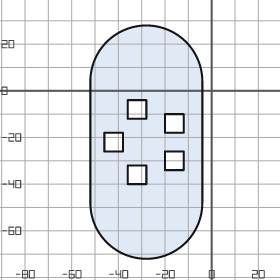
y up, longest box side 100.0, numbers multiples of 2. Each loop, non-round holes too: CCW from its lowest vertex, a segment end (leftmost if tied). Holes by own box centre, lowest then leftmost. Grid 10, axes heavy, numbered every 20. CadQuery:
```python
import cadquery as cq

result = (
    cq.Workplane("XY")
    .moveTo(-52.0, -48.0)
    .threePointArc((-28.0, -72.0), (-4.0, -48.0))
    .lineTo(-4.0, 4.0)
    .threePointArc((-28.0, 28.0), (-52.0, 4.0))
    .close()
    .moveTo(-36.0, -40.0)
    .lineTo(-28.0, -40.0)
    .lineTo(-28.0, -32.0)
    .lineTo(-36.0, -32.0)
    .close()
    .moveTo(-20.0, -34.0)
    .lineTo(-12.0, -34.0)
    .lineTo(-12.0, -26.0)
    .lineTo(-20.0, -26.0)
    .close()
    .moveTo(-46.0, -26.0)
    .lineTo(-38.0, -26.0)
    .lineTo(-38.0, -18.0)
    .lineTo(-46.0, -18.0)
    .close()
    .moveTo(-20.0, -18.0)
    .lineTo(-12.0, -18.0)
    .lineTo(-12.0, -10.0)
    .lineTo(-20.0, -10.0)
    .close()
    .moveTo(-36.0, -12.0)
    .lineTo(-28.0, -12.0)
    .lineTo(-28.0, -4.0)
    .lineTo(-36.0, -4.0)
    .close()
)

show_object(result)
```